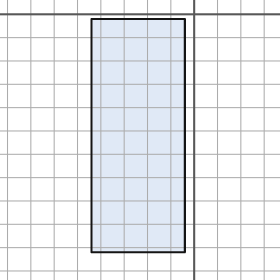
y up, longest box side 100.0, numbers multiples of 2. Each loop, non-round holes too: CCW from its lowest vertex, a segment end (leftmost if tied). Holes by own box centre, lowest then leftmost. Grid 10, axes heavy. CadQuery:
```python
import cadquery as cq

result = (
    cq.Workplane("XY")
    .moveTo(-44.0, -102.0)
    .lineTo(-4.0, -102.0)
    .lineTo(-4.0, -2.0)
    .lineTo(-44.0, -2.0)
    .close()
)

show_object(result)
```